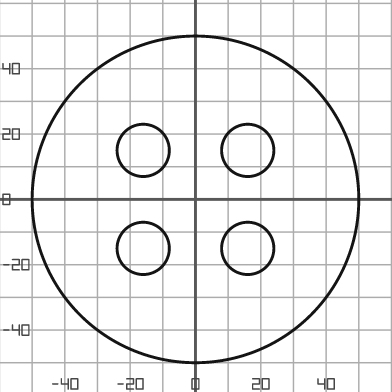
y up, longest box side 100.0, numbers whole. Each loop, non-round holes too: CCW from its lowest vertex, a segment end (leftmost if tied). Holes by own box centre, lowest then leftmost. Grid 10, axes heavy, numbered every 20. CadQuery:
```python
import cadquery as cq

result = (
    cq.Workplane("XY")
    .moveTo(0.0, 0.0)
    .circle(50.0)
    .moveTo(-16.0, -15.0)
    .circle(8.0)
    .moveTo(16.0, -15.0)
    .circle(8.0)
    .moveTo(-16.0, 15.0)
    .circle(8.0)
    .moveTo(16.0, 15.0)
    .circle(8.0)
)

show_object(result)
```